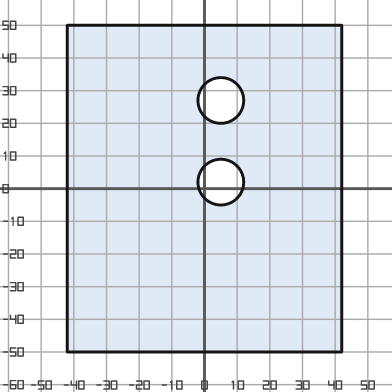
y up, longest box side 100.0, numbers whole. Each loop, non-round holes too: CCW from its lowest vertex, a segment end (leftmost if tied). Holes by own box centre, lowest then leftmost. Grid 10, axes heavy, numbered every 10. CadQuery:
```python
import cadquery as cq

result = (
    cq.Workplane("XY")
    .moveTo(-42.0, -50.0)
    .lineTo(42.0, -50.0)
    .lineTo(42.0, 50.0)
    .lineTo(-42.0, 50.0)
    .close()
    .moveTo(5.0, 2.0)
    .circle(7.0)
    .moveTo(5.0, 27.0)
    .circle(7.0)
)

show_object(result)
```